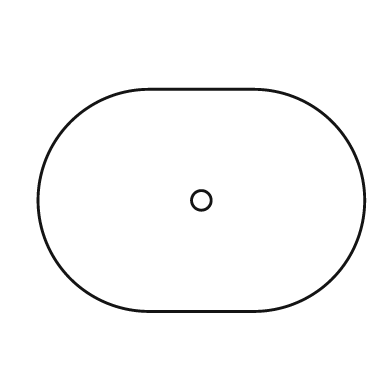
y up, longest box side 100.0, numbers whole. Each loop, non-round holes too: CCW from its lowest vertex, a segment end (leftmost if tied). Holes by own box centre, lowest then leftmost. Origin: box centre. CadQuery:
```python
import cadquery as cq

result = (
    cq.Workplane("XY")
    .moveTo(-16.0, -34.0)
    .lineTo(16.0, -34.0)
    .threePointArc((50.0, 0.0), (16.0, 34.0))
    .lineTo(-16.0, 34.0)
    .threePointArc((-50.0, 0.0), (-16.0, -34.0))
    .close()
    .moveTo(0.0, 0.0)
    .circle(3.0)
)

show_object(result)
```